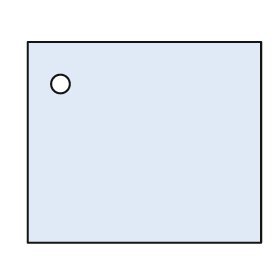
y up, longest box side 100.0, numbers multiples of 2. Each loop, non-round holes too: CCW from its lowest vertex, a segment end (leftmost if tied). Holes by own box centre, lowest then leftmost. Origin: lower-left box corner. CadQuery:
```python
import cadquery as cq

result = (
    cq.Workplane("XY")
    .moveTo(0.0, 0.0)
    .lineTo(100.0, 0.0)
    .lineTo(100.0, 86.0)
    .lineTo(0.0, 86.0)
    .close()
    .moveTo(14.0, 68.0)
    .circle(4.0)
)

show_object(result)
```